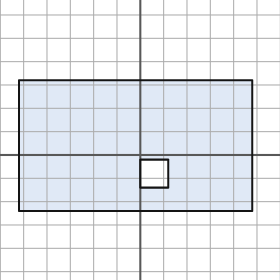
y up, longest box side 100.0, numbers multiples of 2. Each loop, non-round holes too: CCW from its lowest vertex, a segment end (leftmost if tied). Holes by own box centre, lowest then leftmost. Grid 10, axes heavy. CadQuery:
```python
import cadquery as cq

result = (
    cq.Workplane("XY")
    .moveTo(-52.0, -24.0)
    .lineTo(48.0, -24.0)
    .lineTo(48.0, 32.0)
    .lineTo(-52.0, 32.0)
    .close()
    .moveTo(0.0, -14.0)
    .lineTo(12.0, -14.0)
    .lineTo(12.0, -2.0)
    .lineTo(0.0, -2.0)
    .close()
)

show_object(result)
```